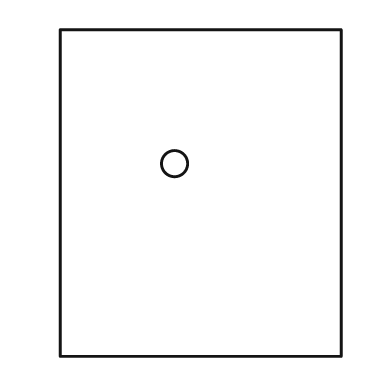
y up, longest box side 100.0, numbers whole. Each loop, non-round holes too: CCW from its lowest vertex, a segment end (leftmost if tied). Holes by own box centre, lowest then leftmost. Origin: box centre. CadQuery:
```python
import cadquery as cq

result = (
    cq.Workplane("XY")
    .moveTo(-43.0, -50.0)
    .lineTo(43.0, -50.0)
    .lineTo(43.0, 50.0)
    .lineTo(-43.0, 50.0)
    .close()
    .moveTo(-8.0, 9.0)
    .circle(4.0)
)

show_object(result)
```